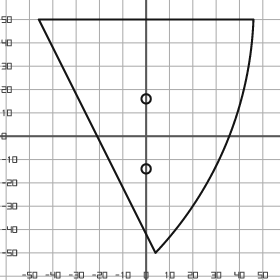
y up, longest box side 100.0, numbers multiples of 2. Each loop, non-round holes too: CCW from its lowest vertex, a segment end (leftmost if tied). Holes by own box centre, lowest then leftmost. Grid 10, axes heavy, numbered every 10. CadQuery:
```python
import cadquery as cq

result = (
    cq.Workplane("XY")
    .moveTo(4.0, -50.0)
    .threePointArc((34.0, -4.0), (46.0, 50.0))
    .lineTo(-46.0, 50.0)
    .close()
    .moveTo(0.0, -14.0)
    .circle(2.0)
    .moveTo(0.0, 16.0)
    .circle(2.0)
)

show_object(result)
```